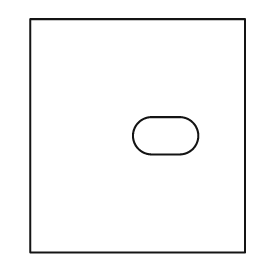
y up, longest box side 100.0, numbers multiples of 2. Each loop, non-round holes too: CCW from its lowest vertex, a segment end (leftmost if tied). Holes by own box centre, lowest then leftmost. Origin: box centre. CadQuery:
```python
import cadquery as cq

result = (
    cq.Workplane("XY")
    .moveTo(-46.0, -50.0)
    .lineTo(46.0, -50.0)
    .lineTo(46.0, 50.0)
    .lineTo(-46.0, 50.0)
    .close()
    .moveTo(6.0, -8.0)
    .lineTo(18.0, -8.0)
    .threePointArc((26.0, 0.0), (18.0, 8.0))
    .lineTo(6.0, 8.0)
    .threePointArc((-2.0, 0.0), (6.0, -8.0))
    .close()
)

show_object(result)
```